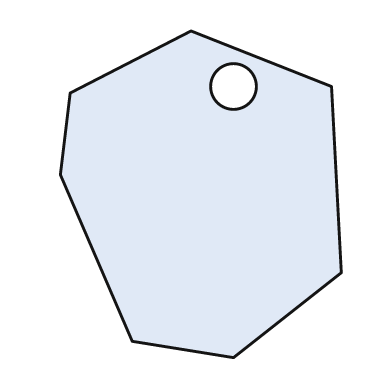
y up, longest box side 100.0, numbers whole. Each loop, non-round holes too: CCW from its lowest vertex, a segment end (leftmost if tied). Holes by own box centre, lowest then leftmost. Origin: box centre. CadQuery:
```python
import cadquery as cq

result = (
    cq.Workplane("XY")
    .moveTo(10.0, -50.0)
    .lineTo(43.0, -24.0)
    .lineTo(40.0, 33.0)
    .lineTo(-3.0, 50.0)
    .lineTo(-40.0, 31.0)
    .lineTo(-43.0, 6.0)
    .lineTo(-21.0, -45.0)
    .close()
    .moveTo(10.0, 33.0)
    .circle(7.0)
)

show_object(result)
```